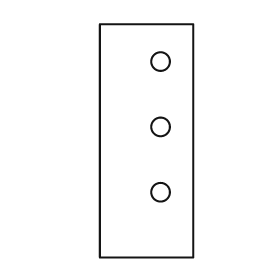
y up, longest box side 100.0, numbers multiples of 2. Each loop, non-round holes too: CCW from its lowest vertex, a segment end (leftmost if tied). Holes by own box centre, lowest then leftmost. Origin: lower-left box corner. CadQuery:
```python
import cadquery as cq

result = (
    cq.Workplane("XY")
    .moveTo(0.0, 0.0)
    .lineTo(40.0, 0.0)
    .lineTo(40.0, 100.0)
    .lineTo(0.0, 100.0)
    .close()
    .moveTo(26.0, 28.0)
    .circle(4.0)
    .moveTo(26.0, 56.0)
    .circle(4.0)
    .moveTo(26.0, 84.0)
    .circle(4.0)
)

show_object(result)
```